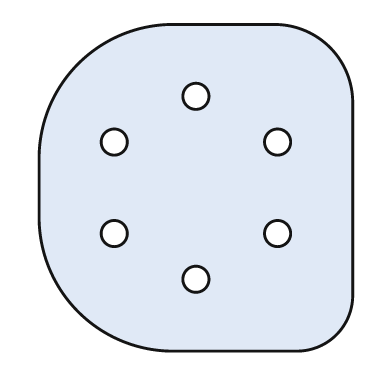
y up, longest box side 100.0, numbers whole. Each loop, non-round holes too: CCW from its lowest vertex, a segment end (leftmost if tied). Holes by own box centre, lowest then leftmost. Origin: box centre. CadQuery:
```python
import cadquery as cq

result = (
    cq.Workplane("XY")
    .moveTo(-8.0, -50.0)
    .lineTo(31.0, -50.0)
    .threePointArc((43.0, -45.0), (48.0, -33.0))
    .lineTo(48.0, 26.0)
    .threePointArc((41.0, 43.0), (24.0, 50.0))
    .lineTo(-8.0, 50.0)
    .threePointArc((-36.0, 38.0), (-48.0, 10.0))
    .lineTo(-48.0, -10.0)
    .threePointArc((-36.0, -38.0), (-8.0, -50.0))
    .close()
    .moveTo(0.0, -28.0)
    .circle(4.0)
    .moveTo(-25.0, -14.0)
    .circle(4.0)
    .moveTo(25.0, -14.0)
    .circle(4.0)
    .moveTo(-25.0, 14.0)
    .circle(4.0)
    .moveTo(25.0, 14.0)
    .circle(4.0)
    .moveTo(0.0, 28.0)
    .circle(4.0)
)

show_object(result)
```